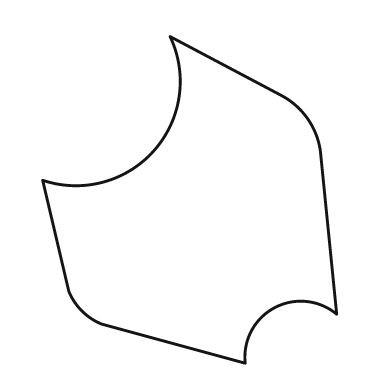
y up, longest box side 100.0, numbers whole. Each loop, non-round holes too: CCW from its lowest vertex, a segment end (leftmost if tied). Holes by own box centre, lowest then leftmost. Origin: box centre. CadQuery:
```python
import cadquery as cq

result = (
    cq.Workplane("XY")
    .moveTo(17.0, -50.0)
    .threePointArc((26.0, -33.0), (45.0, -35.0))
    .lineTo(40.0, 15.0)
    .threePointArc((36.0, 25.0), (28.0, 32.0))
    .lineTo(-6.0, 50.0)
    .threePointArc((-11.0, 15.0), (-45.0, 6.0))
    .lineTo(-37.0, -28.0)
    .threePointArc((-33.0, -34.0), (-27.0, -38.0))
    .close()
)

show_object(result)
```